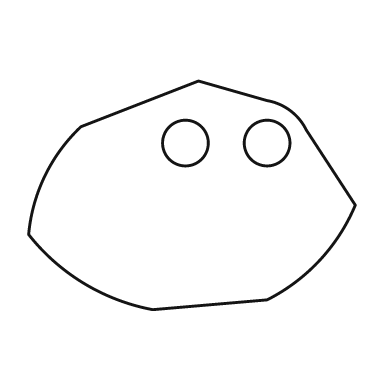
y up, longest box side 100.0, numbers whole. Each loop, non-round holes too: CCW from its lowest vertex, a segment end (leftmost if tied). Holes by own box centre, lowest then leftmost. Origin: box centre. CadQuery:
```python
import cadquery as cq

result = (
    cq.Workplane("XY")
    .moveTo(-12.0, -35.0)
    .lineTo(23.0, -32.0)
    .threePointArc((39.0, -20.0), (50.0, -3.0))
    .lineTo(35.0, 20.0)
    .threePointArc((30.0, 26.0), (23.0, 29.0))
    .lineTo(2.0, 35.0)
    .lineTo(-34.0, 21.0)
    .threePointArc((-45.0, 6.0), (-50.0, -12.0))
    .threePointArc((-33.0, -27.0), (-12.0, -35.0))
    .close()
    .moveTo(-2.0, 16.0)
    .circle(7.0)
    .moveTo(23.0, 16.0)
    .circle(7.0)
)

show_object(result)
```